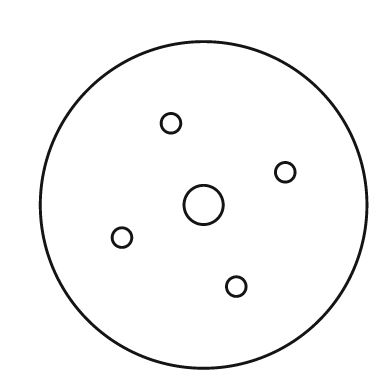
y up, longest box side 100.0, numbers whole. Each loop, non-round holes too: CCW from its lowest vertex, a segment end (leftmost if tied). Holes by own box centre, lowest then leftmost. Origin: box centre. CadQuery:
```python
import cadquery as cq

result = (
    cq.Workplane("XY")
    .moveTo(0.0, 0.0)
    .circle(50.0)
    .moveTo(10.0, -25.0)
    .circle(3.0)
    .moveTo(-25.0, -10.0)
    .circle(3.0)
    .moveTo(0.0, 0.0)
    .circle(6.0)
    .moveTo(25.0, 10.0)
    .circle(3.0)
    .moveTo(-10.0, 25.0)
    .circle(3.0)
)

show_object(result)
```